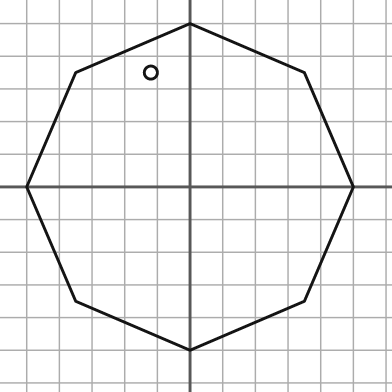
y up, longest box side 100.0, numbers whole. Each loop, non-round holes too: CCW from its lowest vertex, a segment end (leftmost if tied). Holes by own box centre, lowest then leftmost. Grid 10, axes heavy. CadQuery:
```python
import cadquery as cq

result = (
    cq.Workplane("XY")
    .moveTo(0.0, -50.0)
    .lineTo(35.0, -35.0)
    .lineTo(50.0, 0.0)
    .lineTo(35.0, 35.0)
    .lineTo(0.0, 50.0)
    .lineTo(-35.0, 35.0)
    .lineTo(-50.0, 0.0)
    .lineTo(-35.0, -35.0)
    .close()
    .moveTo(-12.0, 35.0)
    .circle(2.0)
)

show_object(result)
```